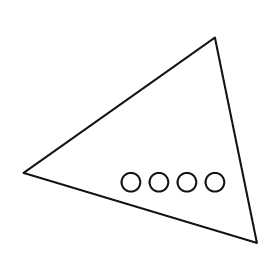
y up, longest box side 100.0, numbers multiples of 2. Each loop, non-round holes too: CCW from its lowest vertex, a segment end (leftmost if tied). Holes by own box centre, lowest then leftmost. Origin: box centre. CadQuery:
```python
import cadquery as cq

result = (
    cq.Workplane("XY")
    .moveTo(50.0, -44.0)
    .lineTo(32.0, 44.0)
    .lineTo(-50.0, -14.0)
    .close()
    .moveTo(-4.0, -18.0)
    .circle(4.0)
    .moveTo(8.0, -18.0)
    .circle(4.0)
    .moveTo(20.0, -18.0)
    .circle(4.0)
    .moveTo(32.0, -18.0)
    .circle(4.0)
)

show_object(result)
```